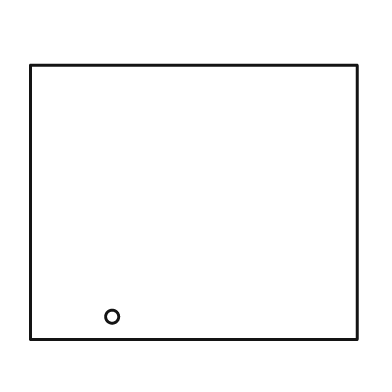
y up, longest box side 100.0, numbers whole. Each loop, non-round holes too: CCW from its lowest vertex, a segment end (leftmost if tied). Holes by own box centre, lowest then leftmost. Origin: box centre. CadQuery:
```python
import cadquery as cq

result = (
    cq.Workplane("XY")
    .moveTo(-50.0, -42.0)
    .lineTo(50.0, -42.0)
    .lineTo(50.0, 42.0)
    .lineTo(-50.0, 42.0)
    .close()
    .moveTo(-25.0, -35.0)
    .circle(2.0)
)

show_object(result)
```